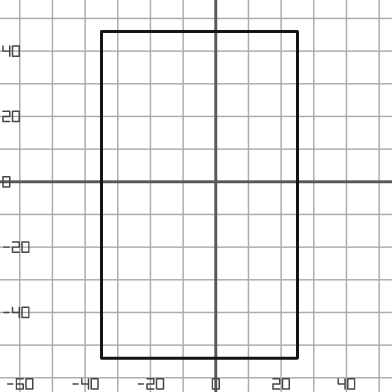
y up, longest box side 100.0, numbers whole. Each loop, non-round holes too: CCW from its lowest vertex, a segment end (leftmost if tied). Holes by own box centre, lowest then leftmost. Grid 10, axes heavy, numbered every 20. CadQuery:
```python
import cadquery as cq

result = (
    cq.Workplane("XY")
    .moveTo(-35.0, -54.0)
    .lineTo(25.0, -54.0)
    .lineTo(25.0, 46.0)
    .lineTo(-35.0, 46.0)
    .close()
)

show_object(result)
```